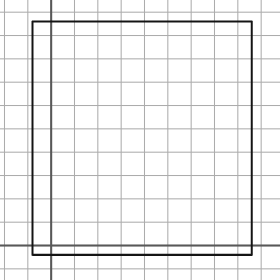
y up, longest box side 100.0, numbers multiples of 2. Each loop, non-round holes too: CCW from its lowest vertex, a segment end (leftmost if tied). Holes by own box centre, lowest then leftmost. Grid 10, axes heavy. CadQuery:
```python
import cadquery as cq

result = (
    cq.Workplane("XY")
    .moveTo(-8.0, -4.0)
    .lineTo(86.0, -4.0)
    .lineTo(86.0, 96.0)
    .lineTo(-8.0, 96.0)
    .close()
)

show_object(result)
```